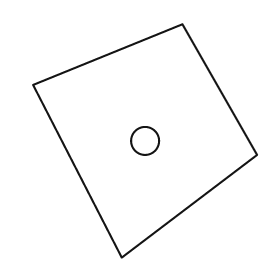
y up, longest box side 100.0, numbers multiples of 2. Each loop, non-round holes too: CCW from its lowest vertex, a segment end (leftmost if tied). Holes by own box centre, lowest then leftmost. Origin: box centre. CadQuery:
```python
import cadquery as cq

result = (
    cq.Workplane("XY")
    .moveTo(-10.0, -50.0)
    .lineTo(48.0, -6.0)
    .lineTo(16.0, 50.0)
    .lineTo(-48.0, 24.0)
    .close()
    .moveTo(0.0, 0.0)
    .circle(6.0)
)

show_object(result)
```